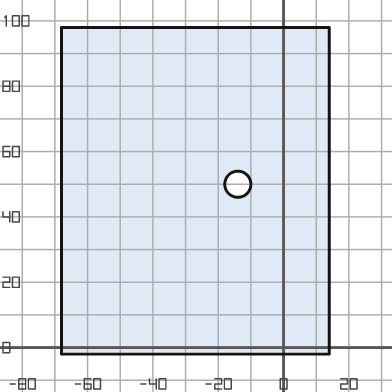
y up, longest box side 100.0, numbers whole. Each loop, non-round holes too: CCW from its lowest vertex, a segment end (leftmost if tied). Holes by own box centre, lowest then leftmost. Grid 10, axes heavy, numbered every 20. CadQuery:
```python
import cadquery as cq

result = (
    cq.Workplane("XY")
    .moveTo(-68.0, -2.0)
    .lineTo(14.0, -2.0)
    .lineTo(14.0, 98.0)
    .lineTo(-68.0, 98.0)
    .close()
    .moveTo(-14.0, 50.0)
    .circle(4.0)
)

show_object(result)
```